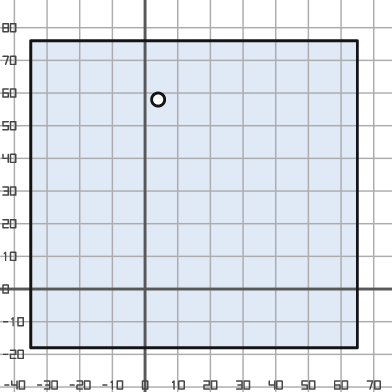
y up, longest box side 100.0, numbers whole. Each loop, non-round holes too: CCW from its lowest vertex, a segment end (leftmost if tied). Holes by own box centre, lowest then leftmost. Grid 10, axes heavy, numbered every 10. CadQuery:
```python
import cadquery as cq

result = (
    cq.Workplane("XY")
    .moveTo(-35.0, -18.0)
    .lineTo(65.0, -18.0)
    .lineTo(65.0, 76.0)
    .lineTo(-35.0, 76.0)
    .close()
    .moveTo(4.0, 58.0)
    .circle(2.0)
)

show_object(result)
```